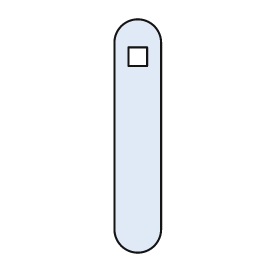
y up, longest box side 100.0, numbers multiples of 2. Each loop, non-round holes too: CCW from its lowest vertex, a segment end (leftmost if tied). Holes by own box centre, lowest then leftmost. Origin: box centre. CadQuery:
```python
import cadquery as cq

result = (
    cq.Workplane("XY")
    .moveTo(-10.0, -40.0)
    .threePointArc((0.0, -50.0), (10.0, -40.0))
    .lineTo(10.0, 40.0)
    .threePointArc((0.0, 50.0), (-10.0, 40.0))
    .close()
    .moveTo(-4.0, 30.0)
    .lineTo(4.0, 30.0)
    .lineTo(4.0, 38.0)
    .lineTo(-4.0, 38.0)
    .close()
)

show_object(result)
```